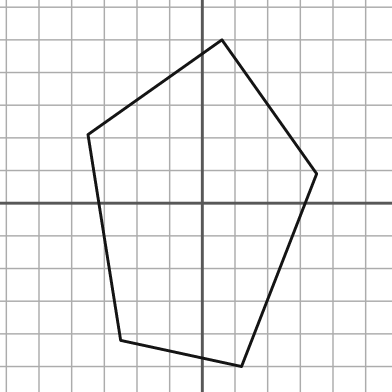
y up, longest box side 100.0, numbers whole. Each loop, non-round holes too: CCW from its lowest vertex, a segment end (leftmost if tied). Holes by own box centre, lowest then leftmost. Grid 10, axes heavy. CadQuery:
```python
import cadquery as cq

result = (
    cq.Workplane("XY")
    .moveTo(12.0, -50.0)
    .lineTo(35.0, 9.0)
    .lineTo(6.0, 50.0)
    .lineTo(-35.0, 21.0)
    .lineTo(-25.0, -42.0)
    .close()
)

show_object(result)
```